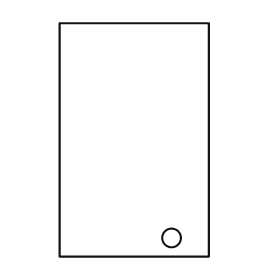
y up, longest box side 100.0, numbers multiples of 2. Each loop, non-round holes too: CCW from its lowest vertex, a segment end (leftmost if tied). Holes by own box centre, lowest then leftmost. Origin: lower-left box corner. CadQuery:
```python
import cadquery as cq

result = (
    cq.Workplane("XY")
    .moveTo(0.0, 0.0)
    .lineTo(64.0, 0.0)
    .lineTo(64.0, 100.0)
    .lineTo(0.0, 100.0)
    .close()
    .moveTo(48.0, 8.0)
    .circle(4.0)
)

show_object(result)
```